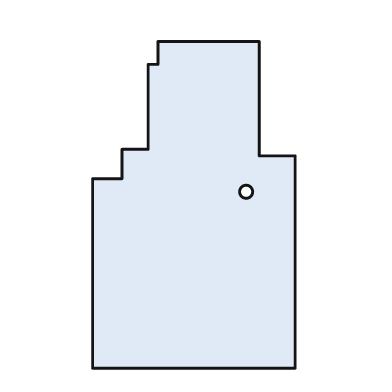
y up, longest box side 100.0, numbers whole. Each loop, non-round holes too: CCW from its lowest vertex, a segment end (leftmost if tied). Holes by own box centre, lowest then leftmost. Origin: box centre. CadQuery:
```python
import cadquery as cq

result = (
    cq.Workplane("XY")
    .moveTo(-31.0, -50.0)
    .lineTo(31.0, -50.0)
    .lineTo(31.0, 15.0)
    .lineTo(20.0, 15.0)
    .lineTo(20.0, 50.0)
    .lineTo(-11.0, 50.0)
    .lineTo(-11.0, 43.0)
    .lineTo(-14.0, 43.0)
    .lineTo(-14.0, 17.0)
    .lineTo(-22.0, 17.0)
    .lineTo(-22.0, 8.0)
    .lineTo(-31.0, 8.0)
    .close()
    .moveTo(16.0, 4.0)
    .circle(2.0)
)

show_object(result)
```